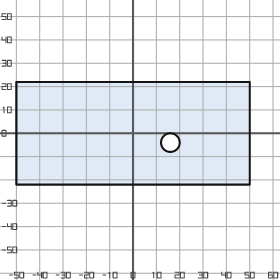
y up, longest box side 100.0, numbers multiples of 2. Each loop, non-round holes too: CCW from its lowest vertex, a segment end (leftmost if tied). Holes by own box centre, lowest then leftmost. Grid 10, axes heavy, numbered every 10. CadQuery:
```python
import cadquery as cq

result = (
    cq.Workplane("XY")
    .moveTo(-50.0, -22.0)
    .lineTo(50.0, -22.0)
    .lineTo(50.0, 22.0)
    .lineTo(-50.0, 22.0)
    .close()
    .moveTo(16.0, -4.0)
    .circle(4.0)
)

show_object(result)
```